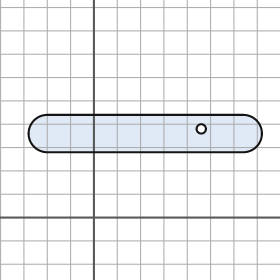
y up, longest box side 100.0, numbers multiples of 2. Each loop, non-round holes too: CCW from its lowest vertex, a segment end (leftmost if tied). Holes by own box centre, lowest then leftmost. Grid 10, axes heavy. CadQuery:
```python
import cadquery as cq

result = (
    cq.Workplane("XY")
    .moveTo(-20.0, 28.0)
    .lineTo(64.0, 28.0)
    .threePointArc((72.0, 36.0), (64.0, 44.0))
    .lineTo(-20.0, 44.0)
    .threePointArc((-28.0, 36.0), (-20.0, 28.0))
    .close()
    .moveTo(46.0, 38.0)
    .circle(2.0)
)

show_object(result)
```